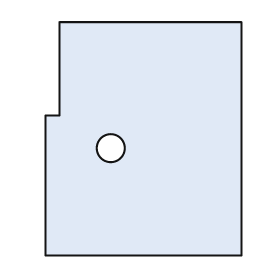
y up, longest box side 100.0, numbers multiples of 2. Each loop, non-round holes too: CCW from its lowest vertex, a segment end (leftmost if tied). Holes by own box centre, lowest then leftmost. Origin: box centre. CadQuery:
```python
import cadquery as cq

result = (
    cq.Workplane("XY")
    .moveTo(-42.0, -50.0)
    .lineTo(42.0, -50.0)
    .lineTo(42.0, 50.0)
    .lineTo(-36.0, 50.0)
    .lineTo(-36.0, 10.0)
    .lineTo(-42.0, 10.0)
    .close()
    .moveTo(-14.0, -4.0)
    .circle(6.0)
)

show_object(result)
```